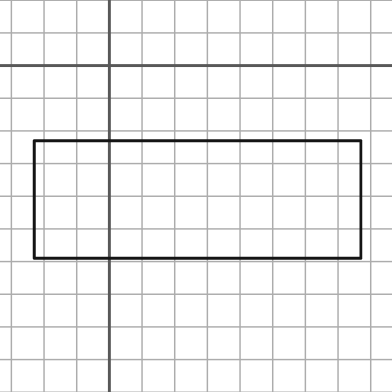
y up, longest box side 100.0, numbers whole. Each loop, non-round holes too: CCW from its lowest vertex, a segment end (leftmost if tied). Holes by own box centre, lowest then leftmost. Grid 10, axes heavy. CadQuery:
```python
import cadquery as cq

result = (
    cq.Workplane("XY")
    .moveTo(-23.0, -59.0)
    .lineTo(77.0, -59.0)
    .lineTo(77.0, -23.0)
    .lineTo(-23.0, -23.0)
    .close()
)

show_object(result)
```